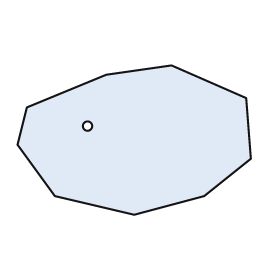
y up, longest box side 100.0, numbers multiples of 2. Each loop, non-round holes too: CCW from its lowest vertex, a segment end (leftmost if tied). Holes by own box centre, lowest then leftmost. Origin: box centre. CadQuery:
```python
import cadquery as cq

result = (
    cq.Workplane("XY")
    .moveTo(0.0, -32.0)
    .lineTo(30.0, -24.0)
    .lineTo(50.0, -8.0)
    .lineTo(48.0, 18.0)
    .lineTo(16.0, 32.0)
    .lineTo(-12.0, 28.0)
    .lineTo(-46.0, 14.0)
    .lineTo(-50.0, -2.0)
    .lineTo(-34.0, -24.0)
    .close()
    .moveTo(-20.0, 6.0)
    .circle(2.0)
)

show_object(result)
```